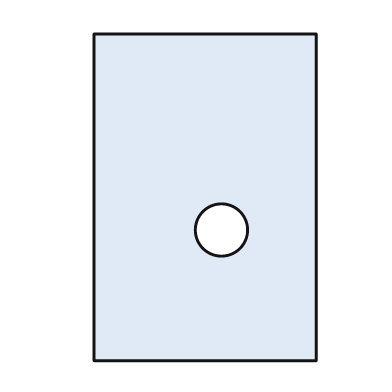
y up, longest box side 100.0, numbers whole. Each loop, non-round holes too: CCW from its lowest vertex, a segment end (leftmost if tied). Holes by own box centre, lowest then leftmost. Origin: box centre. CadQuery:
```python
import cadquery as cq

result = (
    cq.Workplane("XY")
    .moveTo(-34.0, -50.0)
    .lineTo(34.0, -50.0)
    .lineTo(34.0, 50.0)
    .lineTo(-34.0, 50.0)
    .close()
    .moveTo(5.0, -10.0)
    .circle(8.0)
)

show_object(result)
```